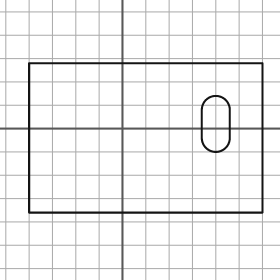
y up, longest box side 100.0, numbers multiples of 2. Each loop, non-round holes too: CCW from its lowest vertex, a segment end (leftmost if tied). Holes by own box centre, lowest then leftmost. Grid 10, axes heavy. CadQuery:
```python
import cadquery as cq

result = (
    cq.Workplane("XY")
    .moveTo(-40.0, -36.0)
    .lineTo(60.0, -36.0)
    .lineTo(60.0, 28.0)
    .lineTo(-40.0, 28.0)
    .close()
    .moveTo(34.0, -4.0)
    .threePointArc((40.0, -10.0), (46.0, -4.0))
    .lineTo(46.0, 8.0)
    .threePointArc((40.0, 14.0), (34.0, 8.0))
    .close()
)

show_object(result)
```